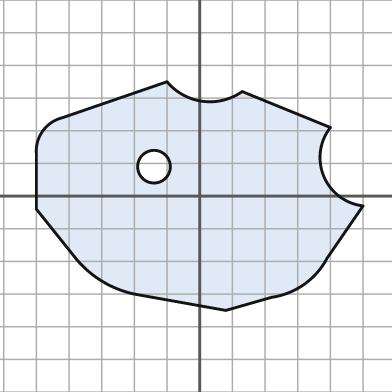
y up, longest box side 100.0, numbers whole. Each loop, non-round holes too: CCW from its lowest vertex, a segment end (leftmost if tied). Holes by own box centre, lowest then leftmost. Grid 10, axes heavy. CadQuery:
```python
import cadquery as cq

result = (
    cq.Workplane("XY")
    .moveTo(8.0, -35.0)
    .lineTo(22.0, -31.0)
    .threePointArc((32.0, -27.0), (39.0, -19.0))
    .lineTo(50.0, -3.0)
    .threePointArc((38.0, 6.0), (40.0, 21.0))
    .lineTo(13.0, 32.0)
    .threePointArc((1.0, 29.0), (-10.0, 35.0))
    .lineTo(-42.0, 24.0)
    .threePointArc((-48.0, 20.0), (-50.0, 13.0))
    .lineTo(-50.0, -4.0)
    .lineTo(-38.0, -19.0)
    .threePointArc((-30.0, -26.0), (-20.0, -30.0))
    .close()
    .moveTo(-14.0, 9.0)
    .circle(5.0)
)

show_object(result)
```